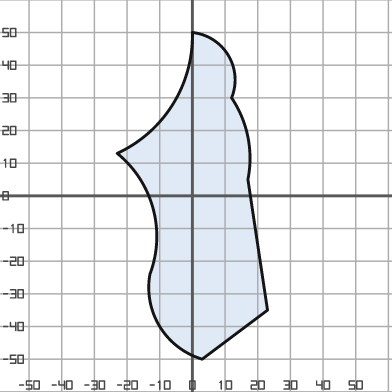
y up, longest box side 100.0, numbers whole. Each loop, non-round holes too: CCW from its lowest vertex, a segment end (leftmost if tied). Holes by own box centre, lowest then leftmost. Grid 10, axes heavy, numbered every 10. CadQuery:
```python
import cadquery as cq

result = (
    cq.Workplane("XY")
    .moveTo(3.0, -50.0)
    .lineTo(23.0, -35.0)
    .lineTo(17.0, 5.0)
    .threePointArc((17.0, 18.0), (12.0, 30.0))
    .threePointArc((11.0, 43.0), (0.0, 50.0))
    .threePointArc((-6.0, 28.0), (-23.0, 13.0))
    .threePointArc((-12.0, -4.0), (-13.0, -24.0))
    .threePointArc((-10.0, -40.0), (3.0, -50.0))
    .close()
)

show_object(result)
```